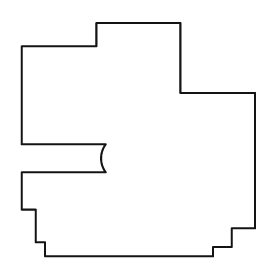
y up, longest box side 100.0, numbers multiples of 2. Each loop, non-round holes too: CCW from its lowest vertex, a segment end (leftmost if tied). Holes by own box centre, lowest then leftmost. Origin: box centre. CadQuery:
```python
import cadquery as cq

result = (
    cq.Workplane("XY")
    .moveTo(-40.0, -50.0)
    .lineTo(32.0, -50.0)
    .lineTo(32.0, -46.0)
    .lineTo(40.0, -46.0)
    .lineTo(40.0, -38.0)
    .lineTo(50.0, -38.0)
    .lineTo(50.0, 20.0)
    .lineTo(18.0, 20.0)
    .lineTo(18.0, 50.0)
    .lineTo(-18.0, 50.0)
    .lineTo(-18.0, 40.0)
    .lineTo(-50.0, 40.0)
    .lineTo(-50.0, -2.0)
    .lineTo(-14.0, -2.0)
    .threePointArc((-16.0, -8.0), (-14.0, -14.0))
    .lineTo(-50.0, -14.0)
    .lineTo(-50.0, -30.0)
    .lineTo(-44.0, -30.0)
    .lineTo(-44.0, -44.0)
    .lineTo(-40.0, -44.0)
    .close()
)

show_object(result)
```